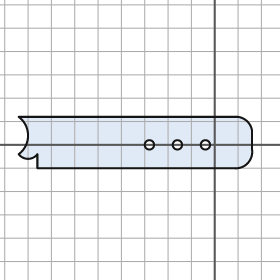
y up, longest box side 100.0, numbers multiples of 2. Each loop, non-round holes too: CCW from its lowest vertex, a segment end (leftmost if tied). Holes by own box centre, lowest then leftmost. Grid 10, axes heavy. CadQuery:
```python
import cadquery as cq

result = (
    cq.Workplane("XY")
    .moveTo(-76.0, -10.0)
    .lineTo(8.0, -10.0)
    .threePointArc((14.0, -8.0), (16.0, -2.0))
    .lineTo(16.0, 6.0)
    .threePointArc((14.0, 10.0), (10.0, 12.0))
    .lineTo(-84.0, 12.0)
    .threePointArc((-80.0, 4.0), (-84.0, -4.0))
    .threePointArc((-80.0, -6.0), (-76.0, -4.0))
    .close()
    .moveTo(-28.0, 0.0)
    .circle(2.0)
    .moveTo(-16.0, 0.0)
    .circle(2.0)
    .moveTo(-4.0, 0.0)
    .circle(2.0)
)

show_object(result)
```